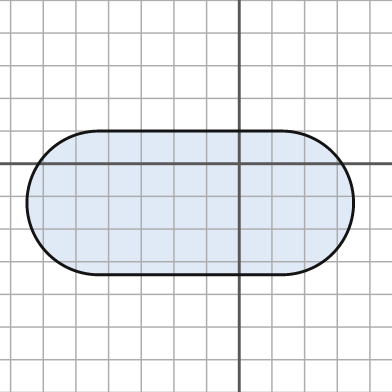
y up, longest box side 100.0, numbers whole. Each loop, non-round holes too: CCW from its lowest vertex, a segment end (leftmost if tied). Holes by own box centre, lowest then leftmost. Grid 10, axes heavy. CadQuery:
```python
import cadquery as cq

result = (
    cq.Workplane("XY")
    .moveTo(-43.0, -34.0)
    .lineTo(13.0, -34.0)
    .threePointArc((35.0, -12.0), (13.0, 10.0))
    .lineTo(-43.0, 10.0)
    .threePointArc((-65.0, -12.0), (-43.0, -34.0))
    .close()
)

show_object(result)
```